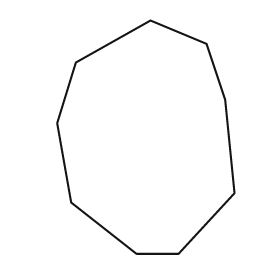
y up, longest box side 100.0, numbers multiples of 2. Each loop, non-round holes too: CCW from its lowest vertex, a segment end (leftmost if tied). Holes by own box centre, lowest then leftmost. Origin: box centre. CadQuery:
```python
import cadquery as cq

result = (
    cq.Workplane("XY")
    .moveTo(-4.0, -50.0)
    .lineTo(14.0, -50.0)
    .lineTo(38.0, -24.0)
    .lineTo(34.0, 16.0)
    .lineTo(26.0, 40.0)
    .lineTo(2.0, 50.0)
    .lineTo(-30.0, 32.0)
    .lineTo(-38.0, 6.0)
    .lineTo(-32.0, -28.0)
    .close()
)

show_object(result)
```